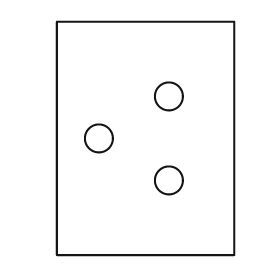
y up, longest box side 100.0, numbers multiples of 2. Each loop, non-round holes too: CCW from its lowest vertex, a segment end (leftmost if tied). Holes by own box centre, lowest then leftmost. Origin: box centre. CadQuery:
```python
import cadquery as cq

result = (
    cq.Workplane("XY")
    .moveTo(-38.0, -50.0)
    .lineTo(38.0, -50.0)
    .lineTo(38.0, 50.0)
    .lineTo(-38.0, 50.0)
    .close()
    .moveTo(10.0, -18.0)
    .circle(6.0)
    .moveTo(-20.0, 0.0)
    .circle(6.0)
    .moveTo(10.0, 18.0)
    .circle(6.0)
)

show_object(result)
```